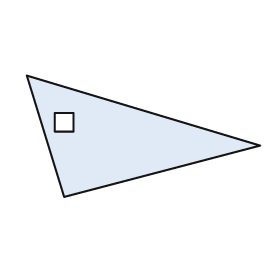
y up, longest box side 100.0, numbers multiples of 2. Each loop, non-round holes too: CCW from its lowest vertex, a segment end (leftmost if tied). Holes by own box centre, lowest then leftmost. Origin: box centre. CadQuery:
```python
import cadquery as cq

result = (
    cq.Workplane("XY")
    .moveTo(-34.0, -26.0)
    .lineTo(50.0, -4.0)
    .lineTo(-50.0, 26.0)
    .close()
    .moveTo(-38.0, 2.0)
    .lineTo(-30.0, 2.0)
    .lineTo(-30.0, 10.0)
    .lineTo(-38.0, 10.0)
    .close()
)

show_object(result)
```